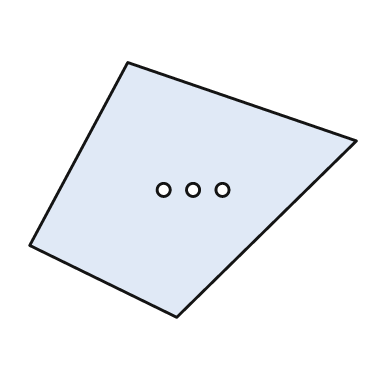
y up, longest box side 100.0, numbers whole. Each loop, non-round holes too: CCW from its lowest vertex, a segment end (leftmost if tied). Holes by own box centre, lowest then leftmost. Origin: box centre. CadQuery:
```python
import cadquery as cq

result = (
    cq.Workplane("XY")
    .moveTo(-5.0, -39.0)
    .lineTo(50.0, 15.0)
    .lineTo(-20.0, 39.0)
    .lineTo(-50.0, -17.0)
    .close()
    .moveTo(-9.0, 0.0)
    .circle(2.0)
    .moveTo(0.0, 0.0)
    .circle(2.0)
    .moveTo(9.0, 0.0)
    .circle(2.0)
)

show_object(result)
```